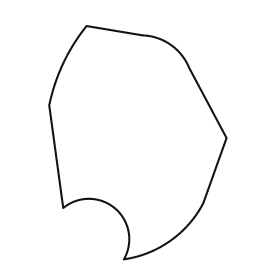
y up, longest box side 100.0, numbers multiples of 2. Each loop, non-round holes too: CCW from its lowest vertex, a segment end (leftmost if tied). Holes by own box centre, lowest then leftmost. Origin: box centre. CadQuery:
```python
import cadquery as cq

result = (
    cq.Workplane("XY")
    .moveTo(-6.0, -50.0)
    .threePointArc((14.0, -42.0), (28.0, -26.0))
    .lineTo(38.0, 2.0)
    .lineTo(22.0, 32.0)
    .threePointArc((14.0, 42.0), (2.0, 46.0))
    .lineTo(-22.0, 50.0)
    .threePointArc((-32.0, 34.0), (-38.0, 16.0))
    .lineTo(-32.0, -28.0)
    .threePointArc((-10.0, -28.0), (-6.0, -50.0))
    .close()
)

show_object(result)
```